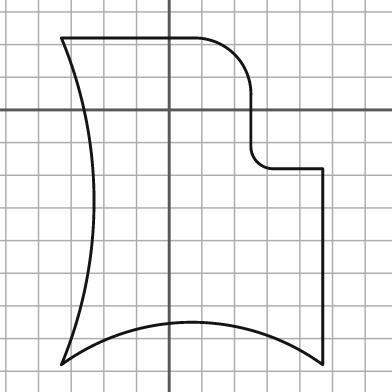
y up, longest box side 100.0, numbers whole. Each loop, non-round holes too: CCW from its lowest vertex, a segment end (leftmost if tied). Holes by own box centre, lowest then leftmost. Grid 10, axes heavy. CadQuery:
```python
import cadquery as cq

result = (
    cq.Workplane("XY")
    .moveTo(-33.0, -78.0)
    .threePointArc((7.0, -65.0), (47.0, -78.0))
    .lineTo(47.0, -18.0)
    .lineTo(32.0, -18.0)
    .threePointArc((27.0, -16.0), (25.0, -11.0))
    .lineTo(25.0, 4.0)
    .threePointArc((20.0, 17.0), (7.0, 22.0))
    .lineTo(-33.0, 22.0)
    .threePointArc((-23.0, -28.0), (-33.0, -78.0))
    .close()
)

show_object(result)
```